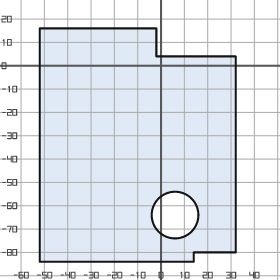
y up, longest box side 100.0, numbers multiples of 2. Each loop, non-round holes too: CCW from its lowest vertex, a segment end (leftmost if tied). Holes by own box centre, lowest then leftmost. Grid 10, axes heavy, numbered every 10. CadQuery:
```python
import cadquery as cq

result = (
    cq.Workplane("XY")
    .moveTo(-52.0, -84.0)
    .lineTo(14.0, -84.0)
    .lineTo(14.0, -80.0)
    .lineTo(32.0, -80.0)
    .lineTo(32.0, 4.0)
    .lineTo(-2.0, 4.0)
    .lineTo(-2.0, 16.0)
    .lineTo(-52.0, 16.0)
    .close()
    .moveTo(6.0, -64.0)
    .circle(10.0)
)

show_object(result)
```